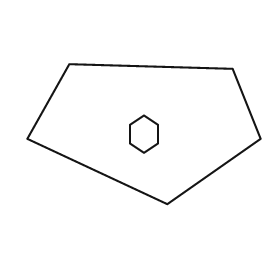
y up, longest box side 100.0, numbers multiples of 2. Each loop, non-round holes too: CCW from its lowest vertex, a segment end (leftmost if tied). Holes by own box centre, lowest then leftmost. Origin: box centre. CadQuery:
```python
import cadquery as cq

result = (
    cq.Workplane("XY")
    .moveTo(10.0, -30.0)
    .lineTo(50.0, -2.0)
    .lineTo(38.0, 28.0)
    .lineTo(-32.0, 30.0)
    .lineTo(-50.0, -2.0)
    .close()
    .moveTo(0.0, -8.0)
    .lineTo(6.0, -4.0)
    .lineTo(6.0, 4.0)
    .lineTo(0.0, 8.0)
    .lineTo(-6.0, 4.0)
    .lineTo(-6.0, -4.0)
    .close()
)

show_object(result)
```